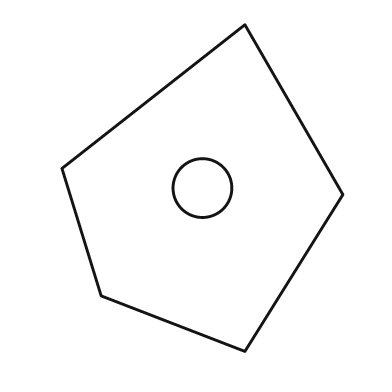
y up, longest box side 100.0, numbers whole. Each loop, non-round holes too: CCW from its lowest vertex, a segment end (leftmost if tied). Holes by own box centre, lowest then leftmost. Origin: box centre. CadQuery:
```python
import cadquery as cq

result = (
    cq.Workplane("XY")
    .moveTo(13.0, -50.0)
    .lineTo(43.0, -2.0)
    .lineTo(13.0, 50.0)
    .lineTo(-43.0, 6.0)
    .lineTo(-31.0, -33.0)
    .close()
    .moveTo(0.0, 0.0)
    .circle(9.0)
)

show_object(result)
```